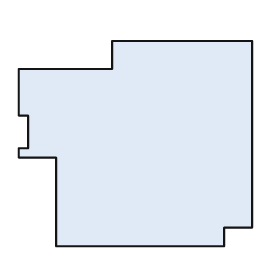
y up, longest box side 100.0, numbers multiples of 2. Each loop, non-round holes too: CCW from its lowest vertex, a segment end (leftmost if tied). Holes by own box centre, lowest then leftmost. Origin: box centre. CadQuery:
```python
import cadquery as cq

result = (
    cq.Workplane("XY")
    .moveTo(-34.0, -44.0)
    .lineTo(38.0, -44.0)
    .lineTo(38.0, -36.0)
    .lineTo(50.0, -36.0)
    .lineTo(50.0, 44.0)
    .lineTo(-10.0, 44.0)
    .lineTo(-10.0, 32.0)
    .lineTo(-50.0, 32.0)
    .lineTo(-50.0, 12.0)
    .lineTo(-46.0, 12.0)
    .lineTo(-46.0, -2.0)
    .lineTo(-50.0, -2.0)
    .lineTo(-50.0, -6.0)
    .lineTo(-34.0, -6.0)
    .close()
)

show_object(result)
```